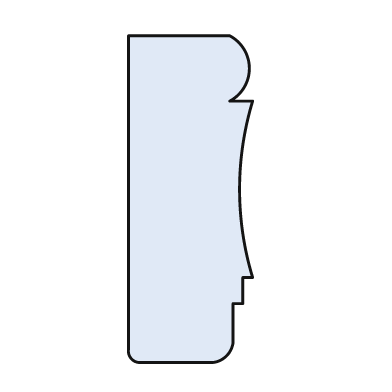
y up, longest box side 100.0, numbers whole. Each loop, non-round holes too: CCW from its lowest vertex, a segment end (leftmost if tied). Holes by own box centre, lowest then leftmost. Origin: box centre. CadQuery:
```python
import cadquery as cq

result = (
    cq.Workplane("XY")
    .moveTo(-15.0, -50.0)
    .lineTo(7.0, -50.0)
    .threePointArc((11.0, -48.0), (13.0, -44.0))
    .lineTo(13.0, -32.0)
    .lineTo(16.0, -32.0)
    .lineTo(16.0, -24.0)
    .lineTo(19.0, -24.0)
    .threePointArc((15.0, 3.0), (19.0, 30.0))
    .lineTo(12.0, 30.0)
    .threePointArc((18.0, 40.0), (12.0, 50.0))
    .lineTo(-19.0, 50.0)
    .lineTo(-19.0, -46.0)
    .threePointArc((-18.0, -49.0), (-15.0, -50.0))
    .close()
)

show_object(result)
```